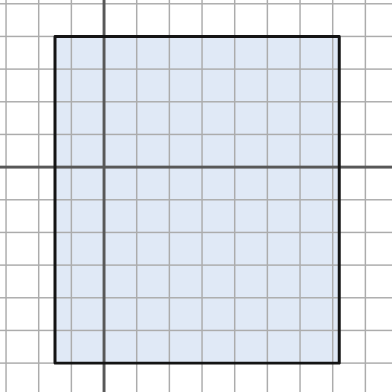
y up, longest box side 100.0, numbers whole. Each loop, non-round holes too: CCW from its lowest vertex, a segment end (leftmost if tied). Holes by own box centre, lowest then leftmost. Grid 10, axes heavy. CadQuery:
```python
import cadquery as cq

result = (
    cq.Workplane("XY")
    .moveTo(-15.0, -60.0)
    .lineTo(72.0, -60.0)
    .lineTo(72.0, 40.0)
    .lineTo(-15.0, 40.0)
    .close()
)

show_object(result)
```